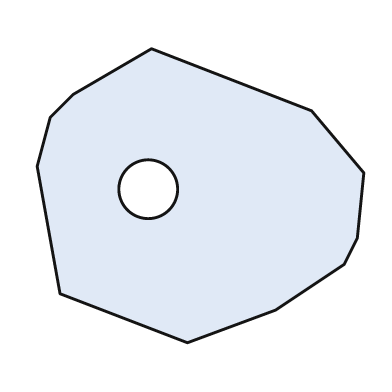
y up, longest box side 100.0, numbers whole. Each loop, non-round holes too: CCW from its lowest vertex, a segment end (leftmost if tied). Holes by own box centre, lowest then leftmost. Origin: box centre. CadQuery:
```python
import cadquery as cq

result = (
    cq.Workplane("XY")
    .moveTo(-4.0, -45.0)
    .lineTo(23.0, -35.0)
    .lineTo(44.0, -21.0)
    .lineTo(48.0, -13.0)
    .lineTo(50.0, 7.0)
    .lineTo(34.0, 26.0)
    .lineTo(-15.0, 45.0)
    .lineTo(-39.0, 31.0)
    .lineTo(-46.0, 24.0)
    .lineTo(-50.0, 9.0)
    .lineTo(-43.0, -30.0)
    .close()
    .moveTo(-16.0, 2.0)
    .circle(9.0)
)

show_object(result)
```